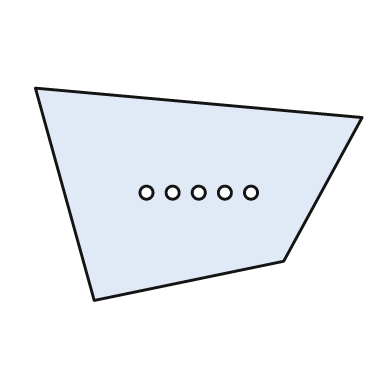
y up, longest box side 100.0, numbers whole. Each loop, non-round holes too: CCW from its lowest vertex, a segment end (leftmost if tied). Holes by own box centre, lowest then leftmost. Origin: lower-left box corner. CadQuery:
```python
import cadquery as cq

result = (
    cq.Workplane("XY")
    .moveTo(18.0, 0.0)
    .lineTo(76.0, 12.0)
    .lineTo(100.0, 56.0)
    .lineTo(0.0, 65.0)
    .close()
    .moveTo(34.0, 33.0)
    .circle(2.0)
    .moveTo(42.0, 33.0)
    .circle(2.0)
    .moveTo(50.0, 33.0)
    .circle(2.0)
    .moveTo(58.0, 33.0)
    .circle(2.0)
    .moveTo(66.0, 33.0)
    .circle(2.0)
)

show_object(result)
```